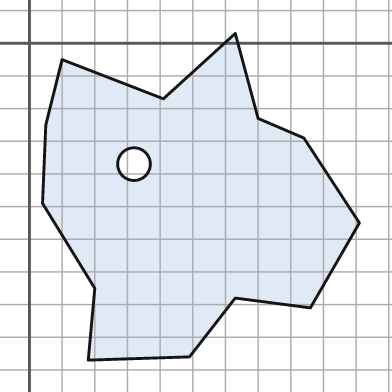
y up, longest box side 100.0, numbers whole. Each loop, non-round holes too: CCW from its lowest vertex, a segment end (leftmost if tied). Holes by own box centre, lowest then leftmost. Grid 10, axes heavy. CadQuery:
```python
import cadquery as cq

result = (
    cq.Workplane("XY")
    .moveTo(18.0, -97.0)
    .lineTo(49.0, -96.0)
    .lineTo(63.0, -78.0)
    .lineTo(86.0, -81.0)
    .lineTo(101.0, -55.0)
    .lineTo(84.0, -29.0)
    .lineTo(70.0, -23.0)
    .lineTo(63.0, 3.0)
    .lineTo(41.0, -17.0)
    .lineTo(10.0, -5.0)
    .lineTo(5.0, -25.0)
    .lineTo(4.0, -49.0)
    .lineTo(20.0, -75.0)
    .close()
    .moveTo(32.0, -37.0)
    .circle(5.0)
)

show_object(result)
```